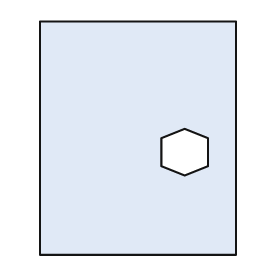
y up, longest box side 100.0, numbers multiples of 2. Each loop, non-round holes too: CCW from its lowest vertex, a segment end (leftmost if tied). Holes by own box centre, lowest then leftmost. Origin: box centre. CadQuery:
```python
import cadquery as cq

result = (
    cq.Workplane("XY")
    .moveTo(-42.0, -50.0)
    .lineTo(42.0, -50.0)
    .lineTo(42.0, 50.0)
    .lineTo(-42.0, 50.0)
    .close()
    .moveTo(20.0, -16.0)
    .lineTo(30.0, -12.0)
    .lineTo(30.0, 0.0)
    .lineTo(20.0, 4.0)
    .lineTo(10.0, 0.0)
    .lineTo(10.0, -12.0)
    .close()
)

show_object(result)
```